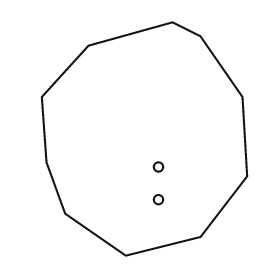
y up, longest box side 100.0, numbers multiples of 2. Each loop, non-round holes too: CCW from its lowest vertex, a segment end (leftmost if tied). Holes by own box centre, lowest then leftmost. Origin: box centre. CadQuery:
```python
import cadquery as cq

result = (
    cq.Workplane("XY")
    .moveTo(-8.0, -50.0)
    .lineTo(24.0, -42.0)
    .lineTo(44.0, -16.0)
    .lineTo(42.0, 18.0)
    .lineTo(24.0, 44.0)
    .lineTo(12.0, 50.0)
    .lineTo(-24.0, 40.0)
    .lineTo(-44.0, 18.0)
    .lineTo(-42.0, -10.0)
    .lineTo(-34.0, -32.0)
    .close()
    .moveTo(6.0, -26.0)
    .circle(2.0)
    .moveTo(6.0, -12.0)
    .circle(2.0)
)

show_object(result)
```